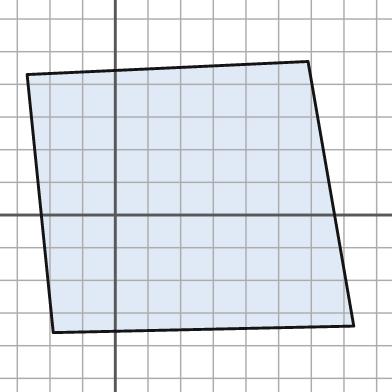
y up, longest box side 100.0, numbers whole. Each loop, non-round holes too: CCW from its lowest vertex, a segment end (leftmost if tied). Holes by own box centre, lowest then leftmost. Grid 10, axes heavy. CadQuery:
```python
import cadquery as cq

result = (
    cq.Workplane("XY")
    .moveTo(-19.0, -36.0)
    .lineTo(73.0, -34.0)
    .lineTo(59.0, 47.0)
    .lineTo(-27.0, 43.0)
    .close()
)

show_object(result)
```